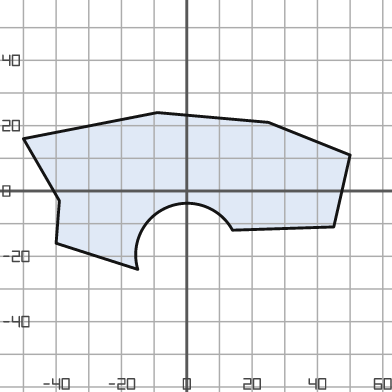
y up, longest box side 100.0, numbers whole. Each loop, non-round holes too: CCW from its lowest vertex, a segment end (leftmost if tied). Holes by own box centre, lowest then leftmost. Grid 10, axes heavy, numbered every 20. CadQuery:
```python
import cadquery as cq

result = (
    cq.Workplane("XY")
    .moveTo(-15.0, -24.0)
    .threePointArc((-6.0, -5.0), (14.0, -12.0))
    .lineTo(45.0, -11.0)
    .lineTo(50.0, 11.0)
    .lineTo(25.0, 21.0)
    .lineTo(-9.0, 24.0)
    .lineTo(-50.0, 16.0)
    .lineTo(-39.0, -3.0)
    .lineTo(-40.0, -16.0)
    .close()
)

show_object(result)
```